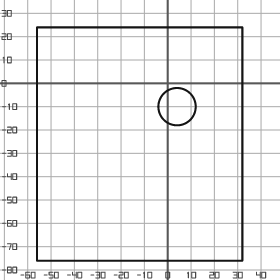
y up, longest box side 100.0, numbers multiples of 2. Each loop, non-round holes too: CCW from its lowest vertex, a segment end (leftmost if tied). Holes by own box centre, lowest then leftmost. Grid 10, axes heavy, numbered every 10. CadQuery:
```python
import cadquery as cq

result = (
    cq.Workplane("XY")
    .moveTo(-56.0, -76.0)
    .lineTo(32.0, -76.0)
    .lineTo(32.0, 24.0)
    .lineTo(-56.0, 24.0)
    .close()
    .moveTo(4.0, -10.0)
    .circle(8.0)
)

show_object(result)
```